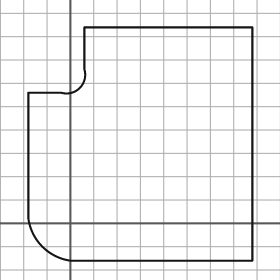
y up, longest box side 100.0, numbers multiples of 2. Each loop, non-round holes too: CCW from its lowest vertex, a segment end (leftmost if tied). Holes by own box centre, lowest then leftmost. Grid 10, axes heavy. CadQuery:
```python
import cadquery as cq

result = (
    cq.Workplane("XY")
    .moveTo(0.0, -16.0)
    .lineTo(78.0, -16.0)
    .lineTo(78.0, 84.0)
    .lineTo(6.0, 84.0)
    .lineTo(6.0, 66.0)
    .threePointArc((4.0, 58.0), (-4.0, 56.0))
    .lineTo(-18.0, 56.0)
    .lineTo(-18.0, 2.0)
    .threePointArc((-12.0, -10.0), (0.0, -16.0))
    .close()
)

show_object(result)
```